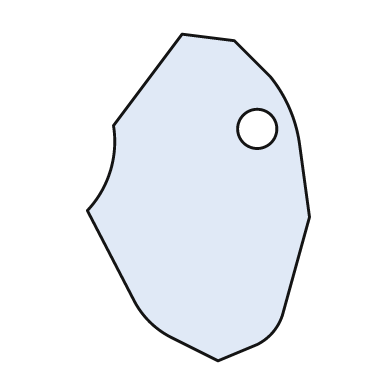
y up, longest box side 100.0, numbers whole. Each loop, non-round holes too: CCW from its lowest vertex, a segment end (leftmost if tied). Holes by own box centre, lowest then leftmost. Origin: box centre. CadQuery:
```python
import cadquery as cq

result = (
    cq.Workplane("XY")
    .moveTo(6.0, -50.0)
    .lineTo(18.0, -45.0)
    .threePointArc((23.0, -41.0), (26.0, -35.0))
    .lineTo(34.0, -6.0)
    .lineTo(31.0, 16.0)
    .threePointArc((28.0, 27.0), (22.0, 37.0))
    .lineTo(11.0, 48.0)
    .lineTo(-5.0, 50.0)
    .lineTo(-26.0, 22.0)
    .threePointArc((-27.0, 8.0), (-34.0, -4.0))
    .lineTo(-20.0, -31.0)
    .threePointArc((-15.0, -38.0), (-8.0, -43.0))
    .close()
    .moveTo(18.0, 21.0)
    .circle(6.0)
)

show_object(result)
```